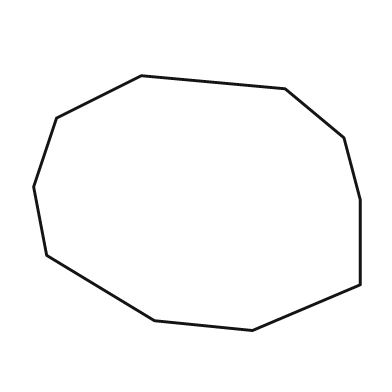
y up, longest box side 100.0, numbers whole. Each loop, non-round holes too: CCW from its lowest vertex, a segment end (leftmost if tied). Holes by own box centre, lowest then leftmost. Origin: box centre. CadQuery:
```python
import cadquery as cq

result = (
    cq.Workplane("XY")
    .moveTo(17.0, -39.0)
    .lineTo(50.0, -25.0)
    .lineTo(50.0, 1.0)
    .lineTo(45.0, 20.0)
    .lineTo(27.0, 35.0)
    .lineTo(-17.0, 39.0)
    .lineTo(-43.0, 26.0)
    .lineTo(-50.0, 5.0)
    .lineTo(-46.0, -16.0)
    .lineTo(-13.0, -36.0)
    .close()
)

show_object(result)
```